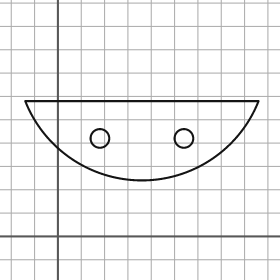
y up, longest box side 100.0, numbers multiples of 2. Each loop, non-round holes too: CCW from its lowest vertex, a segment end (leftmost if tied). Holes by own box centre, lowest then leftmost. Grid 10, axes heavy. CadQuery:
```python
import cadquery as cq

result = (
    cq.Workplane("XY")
    .moveTo(-14.0, 58.0)
    .threePointArc((36.0, 24.0), (86.0, 58.0))
    .close()
    .moveTo(18.0, 42.0)
    .circle(4.0)
    .moveTo(54.0, 42.0)
    .circle(4.0)
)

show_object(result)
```